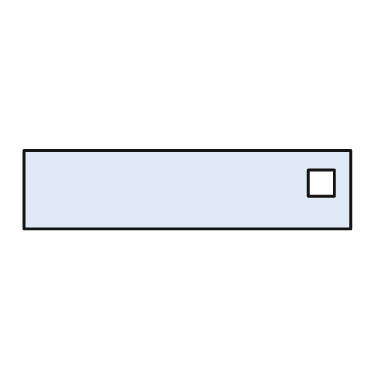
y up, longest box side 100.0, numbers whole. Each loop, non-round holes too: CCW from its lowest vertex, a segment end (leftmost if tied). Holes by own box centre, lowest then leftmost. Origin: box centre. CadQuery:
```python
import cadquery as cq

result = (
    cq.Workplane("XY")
    .moveTo(-50.0, -12.0)
    .lineTo(50.0, -12.0)
    .lineTo(50.0, 12.0)
    .lineTo(-50.0, 12.0)
    .close()
    .moveTo(37.0, -2.0)
    .lineTo(45.0, -2.0)
    .lineTo(45.0, 6.0)
    .lineTo(37.0, 6.0)
    .close()
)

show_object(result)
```